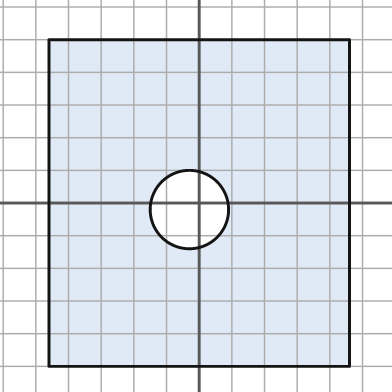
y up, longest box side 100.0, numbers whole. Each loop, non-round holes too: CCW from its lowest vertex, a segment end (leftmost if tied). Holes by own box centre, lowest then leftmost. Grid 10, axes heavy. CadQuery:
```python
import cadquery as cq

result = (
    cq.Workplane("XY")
    .moveTo(-46.0, -50.0)
    .lineTo(46.0, -50.0)
    .lineTo(46.0, 50.0)
    .lineTo(-46.0, 50.0)
    .close()
    .moveTo(-3.0, -2.0)
    .circle(12.0)
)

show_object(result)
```